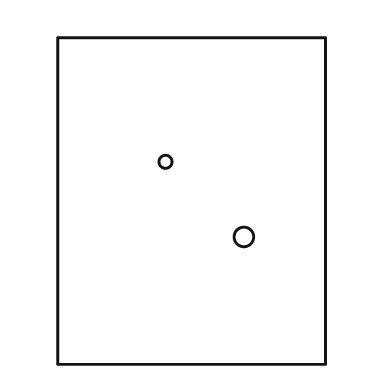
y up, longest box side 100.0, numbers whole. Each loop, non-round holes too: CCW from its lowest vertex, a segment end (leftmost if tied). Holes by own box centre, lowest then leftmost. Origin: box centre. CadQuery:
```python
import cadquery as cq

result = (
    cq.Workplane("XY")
    .moveTo(-41.0, -50.0)
    .lineTo(41.0, -50.0)
    .lineTo(41.0, 50.0)
    .lineTo(-41.0, 50.0)
    .close()
    .moveTo(16.0, -11.0)
    .circle(3.0)
    .moveTo(-8.0, 12.0)
    .circle(2.0)
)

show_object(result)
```